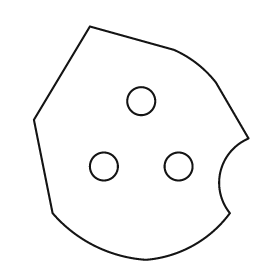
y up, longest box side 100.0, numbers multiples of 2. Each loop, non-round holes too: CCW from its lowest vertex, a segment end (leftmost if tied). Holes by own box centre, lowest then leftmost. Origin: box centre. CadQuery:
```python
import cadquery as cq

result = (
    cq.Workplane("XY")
    .moveTo(2.0, -50.0)
    .threePointArc((22.0, -44.0), (38.0, -30.0))
    .threePointArc((34.0, -12.0), (46.0, 2.0))
    .lineTo(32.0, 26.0)
    .threePointArc((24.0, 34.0), (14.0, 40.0))
    .lineTo(-22.0, 50.0)
    .lineTo(-46.0, 10.0)
    .lineTo(-38.0, -30.0)
    .threePointArc((-20.0, -44.0), (2.0, -50.0))
    .close()
    .moveTo(-16.0, -10.0)
    .circle(6.0)
    .moveTo(16.0, -10.0)
    .circle(6.0)
    .moveTo(0.0, 18.0)
    .circle(6.0)
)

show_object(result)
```